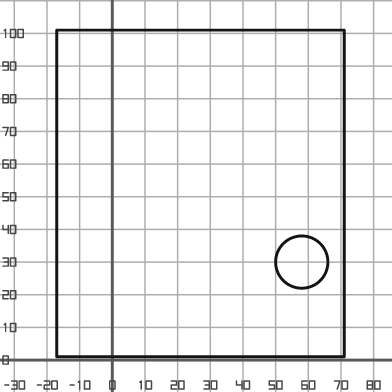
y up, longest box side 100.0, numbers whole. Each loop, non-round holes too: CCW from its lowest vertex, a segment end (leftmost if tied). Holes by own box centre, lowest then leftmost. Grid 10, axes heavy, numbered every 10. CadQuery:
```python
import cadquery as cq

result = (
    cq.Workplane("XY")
    .moveTo(-17.0, 1.0)
    .lineTo(71.0, 1.0)
    .lineTo(71.0, 101.0)
    .lineTo(-17.0, 101.0)
    .close()
    .moveTo(58.0, 30.0)
    .circle(8.0)
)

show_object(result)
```